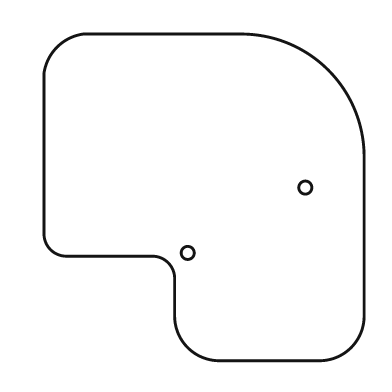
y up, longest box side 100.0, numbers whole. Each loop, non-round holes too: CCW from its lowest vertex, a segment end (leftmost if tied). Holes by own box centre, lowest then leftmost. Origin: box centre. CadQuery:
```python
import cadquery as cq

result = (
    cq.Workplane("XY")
    .moveTo(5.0, -50.0)
    .lineTo(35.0, -50.0)
    .threePointArc((45.0, -46.0), (49.0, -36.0))
    .lineTo(49.0, 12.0)
    .threePointArc((38.0, 39.0), (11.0, 50.0))
    .lineTo(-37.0, 50.0)
    .threePointArc((-45.0, 46.0), (-49.0, 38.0))
    .lineTo(-49.0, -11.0)
    .threePointArc((-47.0, -16.0), (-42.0, -18.0))
    .lineTo(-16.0, -18.0)
    .threePointArc((-11.0, -20.0), (-9.0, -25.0))
    .lineTo(-9.0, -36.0)
    .threePointArc((-5.0, -46.0), (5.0, -50.0))
    .close()
    .moveTo(-5.0, -17.0)
    .circle(2.0)
    .moveTo(31.0, 3.0)
    .circle(2.0)
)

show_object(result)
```